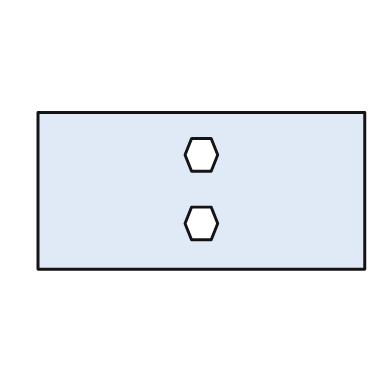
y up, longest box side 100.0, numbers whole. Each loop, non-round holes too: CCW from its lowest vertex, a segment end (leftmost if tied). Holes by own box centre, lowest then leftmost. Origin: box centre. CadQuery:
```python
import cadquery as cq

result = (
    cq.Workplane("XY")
    .moveTo(-50.0, -24.0)
    .lineTo(50.0, -24.0)
    .lineTo(50.0, 24.0)
    .lineTo(-50.0, 24.0)
    .close()
    .moveTo(-3.0, -15.0)
    .lineTo(3.0, -15.0)
    .lineTo(5.0, -10.0)
    .lineTo(3.0, -5.0)
    .lineTo(-3.0, -5.0)
    .lineTo(-5.0, -10.0)
    .close()
    .moveTo(-3.0, 6.0)
    .lineTo(3.0, 6.0)
    .lineTo(5.0, 11.0)
    .lineTo(3.0, 16.0)
    .lineTo(-3.0, 16.0)
    .lineTo(-5.0, 11.0)
    .close()
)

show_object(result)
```